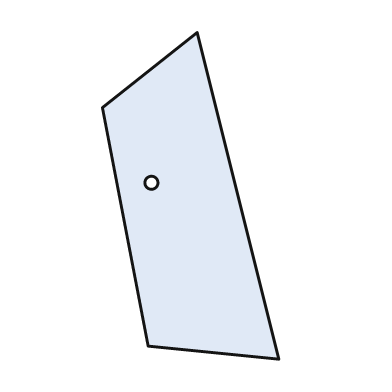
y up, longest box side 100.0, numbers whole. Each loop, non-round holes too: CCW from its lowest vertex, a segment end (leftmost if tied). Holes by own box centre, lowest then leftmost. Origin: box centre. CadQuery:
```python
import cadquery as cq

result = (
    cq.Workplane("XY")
    .moveTo(27.0, -50.0)
    .lineTo(2.0, 50.0)
    .lineTo(-27.0, 27.0)
    .lineTo(-13.0, -46.0)
    .close()
    .moveTo(-12.0, 4.0)
    .circle(2.0)
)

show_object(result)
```